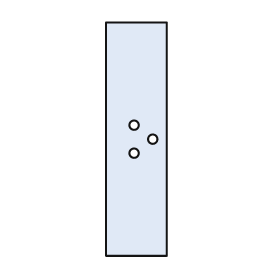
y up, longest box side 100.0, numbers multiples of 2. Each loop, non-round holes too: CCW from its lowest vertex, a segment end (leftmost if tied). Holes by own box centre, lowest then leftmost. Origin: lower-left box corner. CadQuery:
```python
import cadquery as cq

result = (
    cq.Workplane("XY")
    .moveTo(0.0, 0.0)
    .lineTo(26.0, 0.0)
    .lineTo(26.0, 100.0)
    .lineTo(0.0, 100.0)
    .close()
    .moveTo(12.0, 44.0)
    .circle(2.0)
    .moveTo(20.0, 50.0)
    .circle(2.0)
    .moveTo(12.0, 56.0)
    .circle(2.0)
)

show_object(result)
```